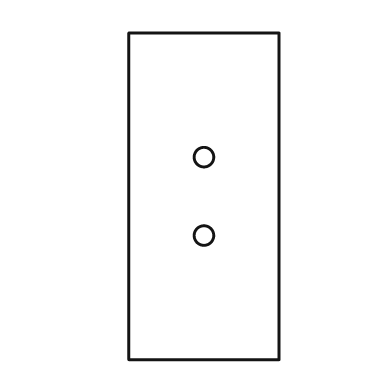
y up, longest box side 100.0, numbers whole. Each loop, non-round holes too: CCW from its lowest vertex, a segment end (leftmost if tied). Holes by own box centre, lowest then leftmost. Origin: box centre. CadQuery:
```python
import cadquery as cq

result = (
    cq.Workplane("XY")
    .moveTo(-23.0, -50.0)
    .lineTo(23.0, -50.0)
    .lineTo(23.0, 50.0)
    .lineTo(-23.0, 50.0)
    .close()
    .moveTo(0.0, -12.0)
    .circle(3.0)
    .moveTo(0.0, 12.0)
    .circle(3.0)
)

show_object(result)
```